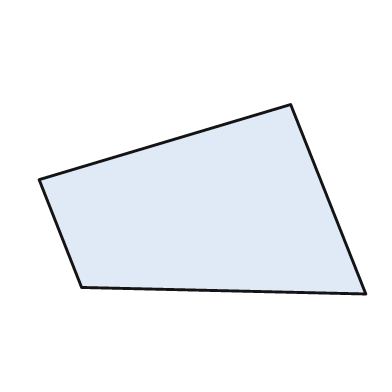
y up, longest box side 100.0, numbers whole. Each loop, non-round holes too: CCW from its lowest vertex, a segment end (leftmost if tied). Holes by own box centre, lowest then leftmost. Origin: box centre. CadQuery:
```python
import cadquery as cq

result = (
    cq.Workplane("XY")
    .moveTo(50.0, -29.0)
    .lineTo(27.0, 29.0)
    .lineTo(-50.0, 6.0)
    .lineTo(-37.0, -27.0)
    .close()
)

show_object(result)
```